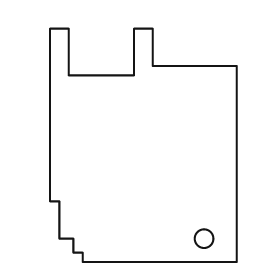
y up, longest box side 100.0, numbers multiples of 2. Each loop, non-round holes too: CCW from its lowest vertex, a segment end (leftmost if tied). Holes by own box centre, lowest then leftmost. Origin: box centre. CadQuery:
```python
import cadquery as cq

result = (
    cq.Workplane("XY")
    .moveTo(-26.0, -50.0)
    .lineTo(40.0, -50.0)
    .lineTo(40.0, 34.0)
    .lineTo(4.0, 34.0)
    .lineTo(4.0, 50.0)
    .lineTo(-4.0, 50.0)
    .lineTo(-4.0, 30.0)
    .lineTo(-32.0, 30.0)
    .lineTo(-32.0, 50.0)
    .lineTo(-40.0, 50.0)
    .lineTo(-40.0, -24.0)
    .lineTo(-36.0, -24.0)
    .lineTo(-36.0, -40.0)
    .lineTo(-30.0, -40.0)
    .lineTo(-30.0, -46.0)
    .lineTo(-26.0, -46.0)
    .close()
    .moveTo(26.0, -40.0)
    .circle(4.0)
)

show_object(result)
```